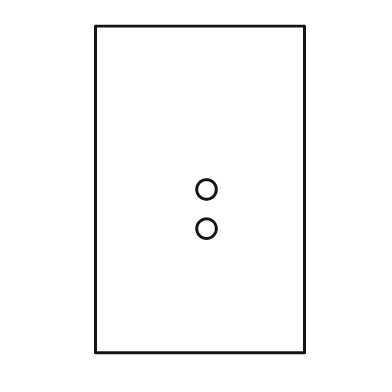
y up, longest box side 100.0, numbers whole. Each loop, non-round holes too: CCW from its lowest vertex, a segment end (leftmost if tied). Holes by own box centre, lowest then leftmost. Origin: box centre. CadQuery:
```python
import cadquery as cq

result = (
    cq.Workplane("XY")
    .moveTo(-32.0, -50.0)
    .lineTo(32.0, -50.0)
    .lineTo(32.0, 50.0)
    .lineTo(-32.0, 50.0)
    .close()
    .moveTo(2.0, -12.0)
    .circle(3.0)
    .moveTo(2.0, 0.0)
    .circle(3.0)
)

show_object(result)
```